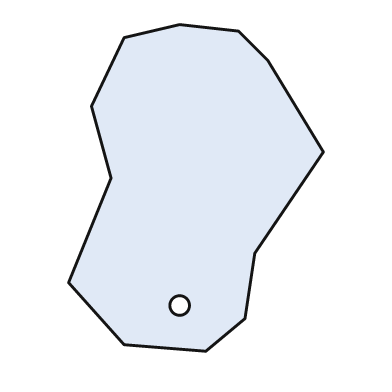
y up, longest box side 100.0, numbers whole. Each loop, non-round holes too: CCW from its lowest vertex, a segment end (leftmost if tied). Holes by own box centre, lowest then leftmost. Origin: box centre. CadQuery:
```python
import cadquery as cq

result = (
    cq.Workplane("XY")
    .moveTo(3.0, -50.0)
    .lineTo(15.0, -40.0)
    .lineTo(18.0, -20.0)
    .lineTo(39.0, 11.0)
    .lineTo(22.0, 39.0)
    .lineTo(13.0, 48.0)
    .lineTo(-5.0, 50.0)
    .lineTo(-22.0, 46.0)
    .lineTo(-32.0, 25.0)
    .lineTo(-26.0, 3.0)
    .lineTo(-39.0, -29.0)
    .lineTo(-22.0, -48.0)
    .close()
    .moveTo(-5.0, -36.0)
    .circle(3.0)
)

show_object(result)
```